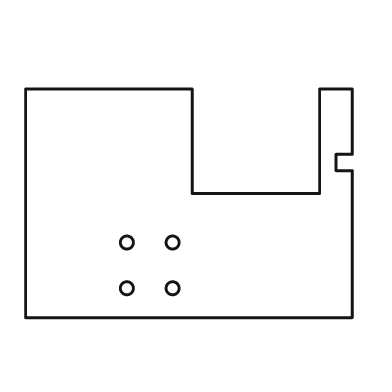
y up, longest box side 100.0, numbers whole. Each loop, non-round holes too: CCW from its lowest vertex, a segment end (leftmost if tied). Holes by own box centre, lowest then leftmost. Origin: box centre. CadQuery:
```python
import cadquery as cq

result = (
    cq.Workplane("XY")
    .moveTo(-50.0, -35.0)
    .lineTo(50.0, -35.0)
    .lineTo(50.0, 10.0)
    .lineTo(45.0, 10.0)
    .lineTo(45.0, 15.0)
    .lineTo(50.0, 15.0)
    .lineTo(50.0, 35.0)
    .lineTo(40.0, 35.0)
    .lineTo(40.0, 3.0)
    .lineTo(1.0, 3.0)
    .lineTo(1.0, 35.0)
    .lineTo(-50.0, 35.0)
    .close()
    .moveTo(-19.0, -26.0)
    .circle(2.0)
    .moveTo(-5.0, -26.0)
    .circle(2.0)
    .moveTo(-19.0, -12.0)
    .circle(2.0)
    .moveTo(-5.0, -12.0)
    .circle(2.0)
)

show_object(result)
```